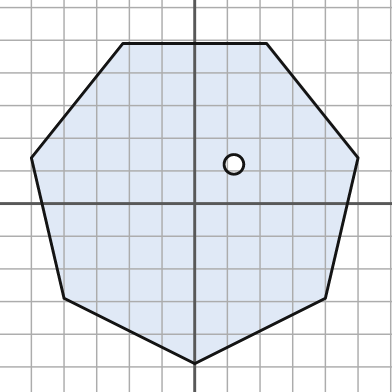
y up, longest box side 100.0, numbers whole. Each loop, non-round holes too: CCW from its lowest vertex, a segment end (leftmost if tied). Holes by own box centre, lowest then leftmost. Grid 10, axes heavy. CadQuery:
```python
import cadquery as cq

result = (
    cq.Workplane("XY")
    .moveTo(0.0, -49.0)
    .lineTo(40.0, -29.0)
    .lineTo(50.0, 14.0)
    .lineTo(22.0, 49.0)
    .lineTo(-22.0, 49.0)
    .lineTo(-50.0, 14.0)
    .lineTo(-40.0, -29.0)
    .close()
    .moveTo(12.0, 12.0)
    .circle(3.0)
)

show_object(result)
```